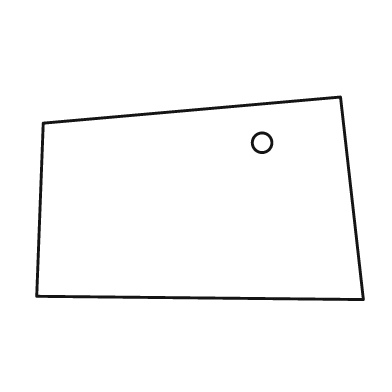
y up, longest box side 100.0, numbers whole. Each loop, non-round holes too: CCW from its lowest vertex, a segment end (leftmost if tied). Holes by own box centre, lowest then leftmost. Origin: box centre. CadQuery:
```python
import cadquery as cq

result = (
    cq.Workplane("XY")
    .moveTo(50.0, -31.0)
    .lineTo(43.0, 31.0)
    .lineTo(-48.0, 23.0)
    .lineTo(-50.0, -30.0)
    .close()
    .moveTo(19.0, 17.0)
    .circle(3.0)
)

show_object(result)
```